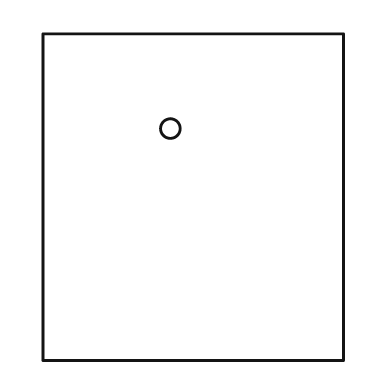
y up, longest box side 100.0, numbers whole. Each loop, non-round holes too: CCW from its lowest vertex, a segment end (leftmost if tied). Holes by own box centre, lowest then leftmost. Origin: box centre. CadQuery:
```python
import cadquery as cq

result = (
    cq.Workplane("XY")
    .moveTo(-46.0, -50.0)
    .lineTo(46.0, -50.0)
    .lineTo(46.0, 50.0)
    .lineTo(-46.0, 50.0)
    .close()
    .moveTo(-7.0, 21.0)
    .circle(3.0)
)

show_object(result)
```